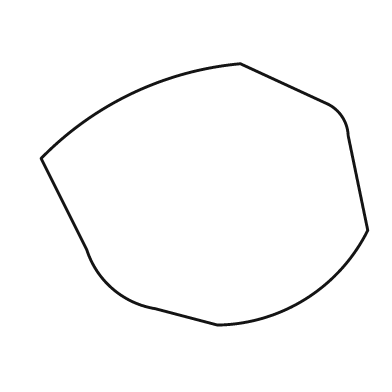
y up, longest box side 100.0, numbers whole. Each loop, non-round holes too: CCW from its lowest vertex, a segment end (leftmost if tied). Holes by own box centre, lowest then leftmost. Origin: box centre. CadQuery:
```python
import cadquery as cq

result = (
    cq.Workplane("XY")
    .moveTo(4.0, -40.0)
    .threePointArc((31.0, -32.0), (50.0, -11.0))
    .lineTo(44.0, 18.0)
    .threePointArc((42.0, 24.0), (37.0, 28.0))
    .lineTo(11.0, 40.0)
    .threePointArc((-22.0, 31.0), (-50.0, 11.0))
    .lineTo(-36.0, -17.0)
    .threePointArc((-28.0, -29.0), (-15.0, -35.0))
    .close()
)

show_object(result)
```